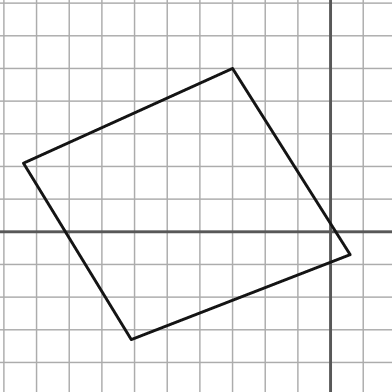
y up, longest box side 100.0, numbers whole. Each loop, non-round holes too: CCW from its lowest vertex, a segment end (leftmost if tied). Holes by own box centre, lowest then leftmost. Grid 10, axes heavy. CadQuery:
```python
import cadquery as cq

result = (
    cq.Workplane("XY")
    .moveTo(-61.0, -33.0)
    .lineTo(6.0, -7.0)
    .lineTo(-30.0, 50.0)
    .lineTo(-94.0, 21.0)
    .close()
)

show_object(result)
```